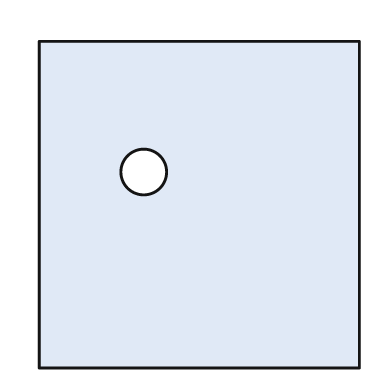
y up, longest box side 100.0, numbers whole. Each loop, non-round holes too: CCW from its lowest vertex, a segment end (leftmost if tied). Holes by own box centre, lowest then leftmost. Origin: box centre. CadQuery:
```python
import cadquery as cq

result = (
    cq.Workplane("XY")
    .moveTo(-49.0, -50.0)
    .lineTo(49.0, -50.0)
    .lineTo(49.0, 50.0)
    .lineTo(-49.0, 50.0)
    .close()
    .moveTo(-17.0, 10.0)
    .circle(7.0)
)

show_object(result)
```